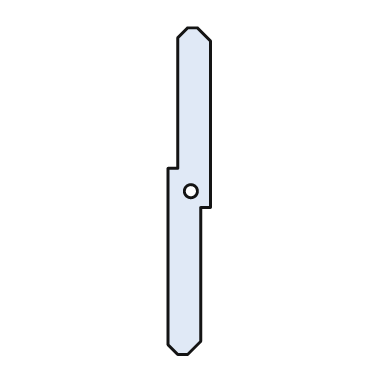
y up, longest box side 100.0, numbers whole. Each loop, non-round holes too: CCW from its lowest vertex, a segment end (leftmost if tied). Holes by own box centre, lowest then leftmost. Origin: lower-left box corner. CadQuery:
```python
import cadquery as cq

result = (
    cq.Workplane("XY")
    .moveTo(3.0, 0.0)
    .lineTo(6.0, 0.0)
    .lineTo(10.0, 4.0)
    .lineTo(10.0, 45.0)
    .lineTo(13.0, 45.0)
    .lineTo(13.0, 96.0)
    .lineTo(9.0, 100.0)
    .lineTo(6.0, 100.0)
    .lineTo(3.0, 97.0)
    .lineTo(3.0, 57.0)
    .lineTo(0.0, 57.0)
    .lineTo(0.0, 3.0)
    .close()
    .moveTo(7.0, 50.0)
    .circle(2.0)
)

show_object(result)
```